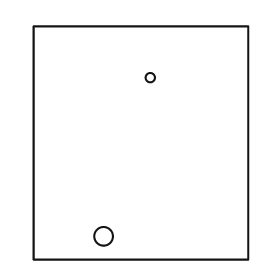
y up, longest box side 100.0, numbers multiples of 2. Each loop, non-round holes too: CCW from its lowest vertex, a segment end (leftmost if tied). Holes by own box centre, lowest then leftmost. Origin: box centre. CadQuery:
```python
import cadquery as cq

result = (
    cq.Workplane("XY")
    .moveTo(-46.0, -50.0)
    .lineTo(46.0, -50.0)
    .lineTo(46.0, 50.0)
    .lineTo(-46.0, 50.0)
    .close()
    .moveTo(-16.0, -40.0)
    .circle(4.0)
    .moveTo(4.0, 28.0)
    .circle(2.0)
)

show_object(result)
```